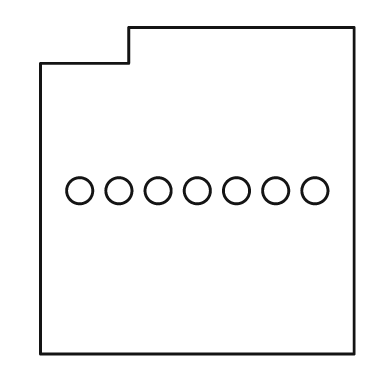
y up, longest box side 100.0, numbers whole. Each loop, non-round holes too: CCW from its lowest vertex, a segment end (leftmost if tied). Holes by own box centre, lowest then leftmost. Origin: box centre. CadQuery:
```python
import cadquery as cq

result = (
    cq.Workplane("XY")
    .moveTo(-48.0, -50.0)
    .lineTo(48.0, -50.0)
    .lineTo(48.0, 50.0)
    .lineTo(-21.0, 50.0)
    .lineTo(-21.0, 39.0)
    .lineTo(-48.0, 39.0)
    .close()
    .moveTo(-36.0, 0.0)
    .circle(4.0)
    .moveTo(-24.0, 0.0)
    .circle(4.0)
    .moveTo(-12.0, 0.0)
    .circle(4.0)
    .moveTo(0.0, 0.0)
    .circle(4.0)
    .moveTo(12.0, 0.0)
    .circle(4.0)
    .moveTo(24.0, 0.0)
    .circle(4.0)
    .moveTo(36.0, 0.0)
    .circle(4.0)
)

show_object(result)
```